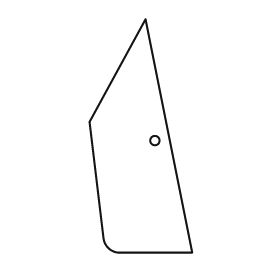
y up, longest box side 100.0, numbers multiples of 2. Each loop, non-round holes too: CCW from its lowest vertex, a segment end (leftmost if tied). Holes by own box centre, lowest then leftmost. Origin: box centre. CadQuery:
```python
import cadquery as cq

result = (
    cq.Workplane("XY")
    .moveTo(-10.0, -50.0)
    .lineTo(22.0, -50.0)
    .lineTo(2.0, 50.0)
    .lineTo(-22.0, 6.0)
    .lineTo(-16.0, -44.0)
    .threePointArc((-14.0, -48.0), (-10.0, -50.0))
    .close()
    .moveTo(6.0, -2.0)
    .circle(2.0)
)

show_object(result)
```